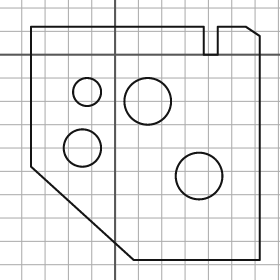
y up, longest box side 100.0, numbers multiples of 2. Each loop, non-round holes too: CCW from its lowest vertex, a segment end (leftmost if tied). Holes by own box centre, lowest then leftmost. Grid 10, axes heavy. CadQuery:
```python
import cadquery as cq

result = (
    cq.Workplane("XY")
    .moveTo(8.0, -88.0)
    .lineTo(62.0, -88.0)
    .lineTo(62.0, 8.0)
    .lineTo(56.0, 12.0)
    .lineTo(44.0, 12.0)
    .lineTo(44.0, 0.0)
    .lineTo(38.0, 0.0)
    .lineTo(38.0, 12.0)
    .lineTo(-36.0, 12.0)
    .lineTo(-36.0, -48.0)
    .close()
    .moveTo(36.0, -52.0)
    .circle(10.0)
    .moveTo(-14.0, -40.0)
    .circle(8.0)
    .moveTo(14.0, -20.0)
    .circle(10.0)
    .moveTo(-12.0, -16.0)
    .circle(6.0)
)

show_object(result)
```